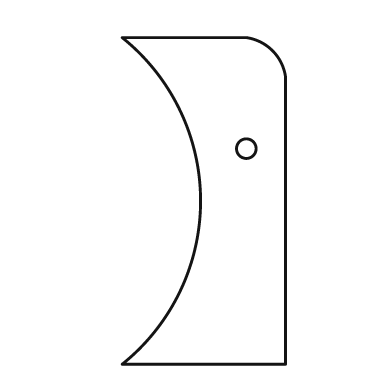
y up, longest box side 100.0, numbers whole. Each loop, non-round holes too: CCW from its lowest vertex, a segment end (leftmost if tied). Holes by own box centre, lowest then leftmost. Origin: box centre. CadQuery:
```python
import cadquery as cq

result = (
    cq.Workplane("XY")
    .moveTo(-25.0, -50.0)
    .lineTo(25.0, -50.0)
    .lineTo(25.0, 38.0)
    .threePointArc((21.0, 46.0), (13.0, 50.0))
    .lineTo(-25.0, 50.0)
    .threePointArc((-1.0, 0.0), (-25.0, -50.0))
    .close()
    .moveTo(13.0, 16.0)
    .circle(3.0)
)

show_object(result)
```